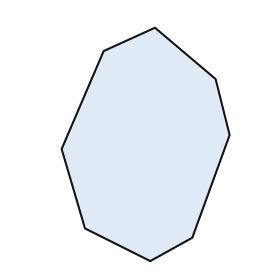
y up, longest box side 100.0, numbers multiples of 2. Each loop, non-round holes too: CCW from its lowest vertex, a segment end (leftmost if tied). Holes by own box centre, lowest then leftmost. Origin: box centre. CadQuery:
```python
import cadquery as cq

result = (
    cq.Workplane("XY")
    .moveTo(2.0, -50.0)
    .lineTo(20.0, -40.0)
    .lineTo(36.0, 4.0)
    .lineTo(30.0, 28.0)
    .lineTo(4.0, 50.0)
    .lineTo(-18.0, 40.0)
    .lineTo(-36.0, -2.0)
    .lineTo(-26.0, -36.0)
    .close()
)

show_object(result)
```